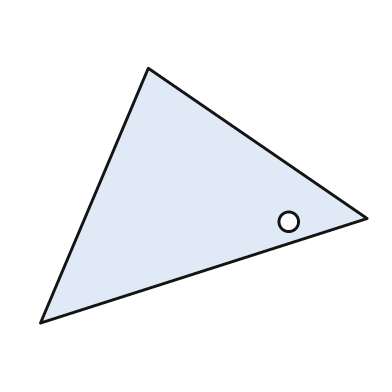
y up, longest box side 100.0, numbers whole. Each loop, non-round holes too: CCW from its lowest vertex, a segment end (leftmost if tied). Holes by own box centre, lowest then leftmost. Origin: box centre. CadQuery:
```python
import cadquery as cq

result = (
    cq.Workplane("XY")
    .moveTo(-50.0, -39.0)
    .lineTo(50.0, -7.0)
    .lineTo(-17.0, 39.0)
    .close()
    .moveTo(26.0, -8.0)
    .circle(3.0)
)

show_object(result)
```